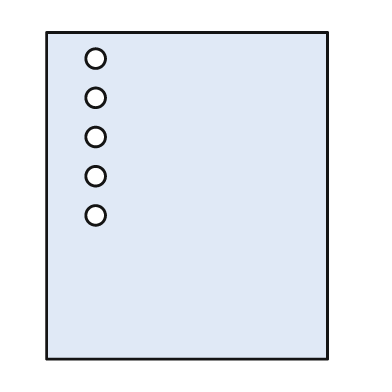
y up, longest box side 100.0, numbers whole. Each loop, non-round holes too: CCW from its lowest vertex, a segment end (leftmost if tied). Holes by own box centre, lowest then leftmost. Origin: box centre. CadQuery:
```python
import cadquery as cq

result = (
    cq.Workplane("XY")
    .moveTo(-43.0, -50.0)
    .lineTo(43.0, -50.0)
    .lineTo(43.0, 50.0)
    .lineTo(-43.0, 50.0)
    .close()
    .moveTo(-28.0, -6.0)
    .circle(3.0)
    .moveTo(-28.0, 6.0)
    .circle(3.0)
    .moveTo(-28.0, 18.0)
    .circle(3.0)
    .moveTo(-28.0, 30.0)
    .circle(3.0)
    .moveTo(-28.0, 42.0)
    .circle(3.0)
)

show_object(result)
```